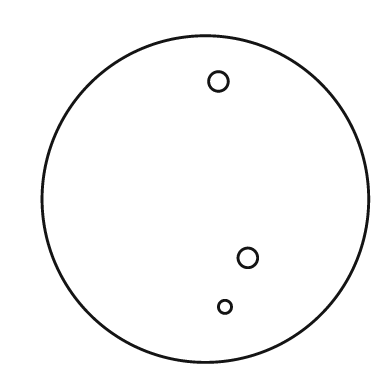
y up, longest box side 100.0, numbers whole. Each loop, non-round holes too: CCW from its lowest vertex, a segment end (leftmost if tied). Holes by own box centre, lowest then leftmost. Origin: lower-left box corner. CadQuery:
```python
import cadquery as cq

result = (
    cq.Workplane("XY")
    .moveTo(50.0, 50.0)
    .circle(50.0)
    .moveTo(56.0, 17.0)
    .circle(2.0)
    .moveTo(63.0, 32.0)
    .circle(3.0)
    .moveTo(54.0, 86.0)
    .circle(3.0)
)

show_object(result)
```